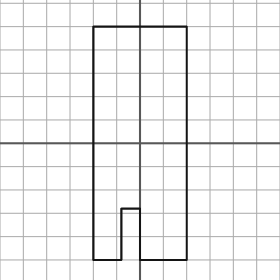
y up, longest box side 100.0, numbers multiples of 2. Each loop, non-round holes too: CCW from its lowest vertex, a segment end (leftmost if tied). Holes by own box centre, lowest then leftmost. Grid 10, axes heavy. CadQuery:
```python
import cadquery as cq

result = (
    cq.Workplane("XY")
    .moveTo(-20.0, -50.0)
    .lineTo(-8.0, -50.0)
    .lineTo(-8.0, -28.0)
    .lineTo(0.0, -28.0)
    .lineTo(0.0, -50.0)
    .lineTo(20.0, -50.0)
    .lineTo(20.0, 50.0)
    .lineTo(-20.0, 50.0)
    .close()
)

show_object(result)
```